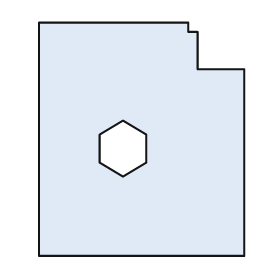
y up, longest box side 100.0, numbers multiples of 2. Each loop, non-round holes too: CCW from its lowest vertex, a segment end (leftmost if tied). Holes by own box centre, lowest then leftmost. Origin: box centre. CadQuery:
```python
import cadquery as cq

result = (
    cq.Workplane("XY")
    .moveTo(-44.0, -50.0)
    .lineTo(44.0, -50.0)
    .lineTo(44.0, 30.0)
    .lineTo(24.0, 30.0)
    .lineTo(24.0, 46.0)
    .lineTo(20.0, 46.0)
    .lineTo(20.0, 50.0)
    .lineTo(-44.0, 50.0)
    .close()
    .moveTo(-8.0, -16.0)
    .lineTo(2.0, -10.0)
    .lineTo(2.0, 2.0)
    .lineTo(-8.0, 8.0)
    .lineTo(-18.0, 2.0)
    .lineTo(-18.0, -10.0)
    .close()
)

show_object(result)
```